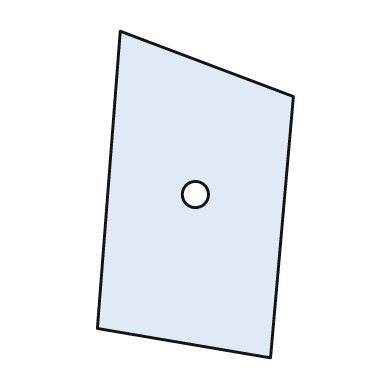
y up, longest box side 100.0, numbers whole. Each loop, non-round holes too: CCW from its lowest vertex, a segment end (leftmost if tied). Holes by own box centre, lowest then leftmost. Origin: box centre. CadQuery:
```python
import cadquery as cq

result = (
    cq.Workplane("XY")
    .moveTo(23.0, -50.0)
    .lineTo(30.0, 30.0)
    .lineTo(-23.0, 50.0)
    .lineTo(-30.0, -41.0)
    .close()
    .moveTo(0.0, 0.0)
    .circle(4.0)
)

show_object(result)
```